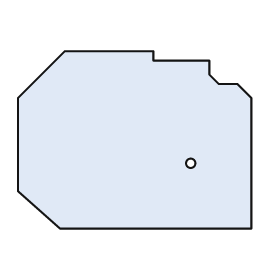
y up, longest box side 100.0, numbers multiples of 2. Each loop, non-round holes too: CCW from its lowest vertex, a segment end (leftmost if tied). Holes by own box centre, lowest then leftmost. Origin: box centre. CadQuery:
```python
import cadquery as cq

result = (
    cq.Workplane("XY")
    .moveTo(-32.0, -38.0)
    .lineTo(50.0, -38.0)
    .lineTo(50.0, 18.0)
    .lineTo(44.0, 24.0)
    .lineTo(36.0, 24.0)
    .lineTo(32.0, 28.0)
    .lineTo(32.0, 34.0)
    .lineTo(8.0, 34.0)
    .lineTo(8.0, 38.0)
    .lineTo(-30.0, 38.0)
    .lineTo(-50.0, 18.0)
    .lineTo(-50.0, -22.0)
    .close()
    .moveTo(24.0, -10.0)
    .circle(2.0)
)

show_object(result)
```